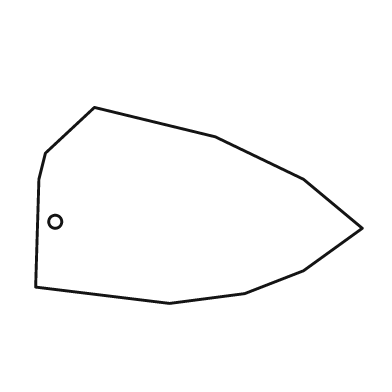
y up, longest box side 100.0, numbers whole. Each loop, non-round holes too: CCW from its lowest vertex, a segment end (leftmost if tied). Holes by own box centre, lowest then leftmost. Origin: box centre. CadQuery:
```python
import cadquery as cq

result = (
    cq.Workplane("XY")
    .moveTo(-9.0, -30.0)
    .lineTo(14.0, -27.0)
    .lineTo(32.0, -20.0)
    .lineTo(50.0, -7.0)
    .lineTo(32.0, 8.0)
    .lineTo(5.0, 21.0)
    .lineTo(-32.0, 30.0)
    .lineTo(-47.0, 16.0)
    .lineTo(-49.0, 8.0)
    .lineTo(-50.0, -25.0)
    .close()
    .moveTo(-44.0, -5.0)
    .circle(2.0)
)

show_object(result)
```